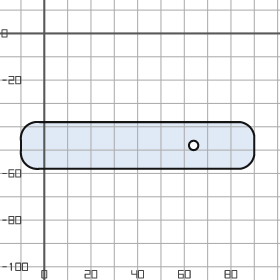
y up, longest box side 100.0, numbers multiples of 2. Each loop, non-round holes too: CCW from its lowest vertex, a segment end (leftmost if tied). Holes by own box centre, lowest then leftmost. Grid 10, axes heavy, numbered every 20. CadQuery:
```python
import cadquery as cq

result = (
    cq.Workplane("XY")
    .moveTo(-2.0, -58.0)
    .lineTo(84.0, -58.0)
    .threePointArc((88.0, -56.0), (90.0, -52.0))
    .lineTo(90.0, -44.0)
    .threePointArc((88.0, -40.0), (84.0, -38.0))
    .lineTo(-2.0, -38.0)
    .threePointArc((-8.0, -40.0), (-10.0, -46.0))
    .lineTo(-10.0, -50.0)
    .threePointArc((-8.0, -56.0), (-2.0, -58.0))
    .close()
    .moveTo(64.0, -48.0)
    .circle(2.0)
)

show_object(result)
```